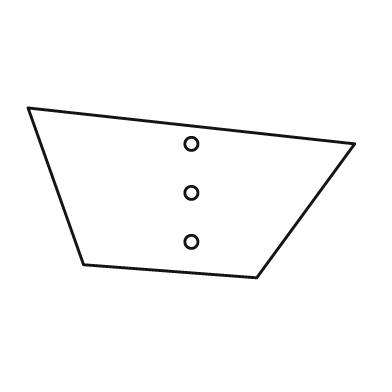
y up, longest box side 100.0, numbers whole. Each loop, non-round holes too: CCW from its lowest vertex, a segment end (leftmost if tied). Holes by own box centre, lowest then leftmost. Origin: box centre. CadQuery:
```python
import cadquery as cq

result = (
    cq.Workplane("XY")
    .moveTo(20.0, -26.0)
    .lineTo(50.0, 15.0)
    .lineTo(-50.0, 26.0)
    .lineTo(-33.0, -22.0)
    .close()
    .moveTo(0.0, -15.0)
    .circle(2.0)
    .moveTo(0.0, 0.0)
    .circle(2.0)
    .moveTo(0.0, 15.0)
    .circle(2.0)
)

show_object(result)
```